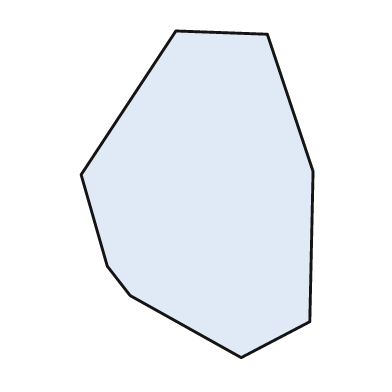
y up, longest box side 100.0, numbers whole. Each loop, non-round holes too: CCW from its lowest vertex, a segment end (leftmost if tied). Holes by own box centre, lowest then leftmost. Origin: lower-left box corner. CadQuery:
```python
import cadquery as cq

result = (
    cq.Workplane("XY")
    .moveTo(49.0, 0.0)
    .lineTo(70.0, 11.0)
    .lineTo(71.0, 57.0)
    .lineTo(57.0, 99.0)
    .lineTo(29.0, 100.0)
    .lineTo(0.0, 56.0)
    .lineTo(8.0, 28.0)
    .lineTo(15.0, 19.0)
    .close()
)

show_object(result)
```